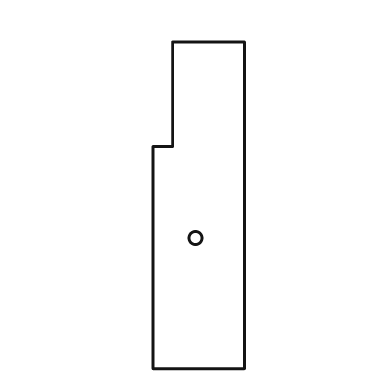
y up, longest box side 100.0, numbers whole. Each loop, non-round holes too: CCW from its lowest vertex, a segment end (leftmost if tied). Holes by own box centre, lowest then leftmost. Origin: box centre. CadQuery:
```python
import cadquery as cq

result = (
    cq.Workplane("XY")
    .moveTo(-14.0, -50.0)
    .lineTo(14.0, -50.0)
    .lineTo(14.0, 50.0)
    .lineTo(-8.0, 50.0)
    .lineTo(-8.0, 18.0)
    .lineTo(-14.0, 18.0)
    .close()
    .moveTo(-1.0, -10.0)
    .circle(2.0)
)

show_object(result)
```